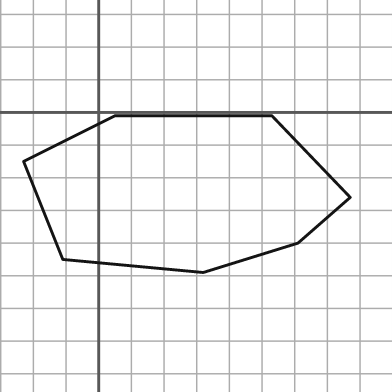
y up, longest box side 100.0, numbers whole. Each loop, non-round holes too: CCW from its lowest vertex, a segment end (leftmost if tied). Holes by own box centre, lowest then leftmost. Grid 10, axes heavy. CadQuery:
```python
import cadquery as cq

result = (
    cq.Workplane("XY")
    .moveTo(32.0, -49.0)
    .lineTo(61.0, -40.0)
    .lineTo(77.0, -26.0)
    .lineTo(53.0, -1.0)
    .lineTo(5.0, -1.0)
    .lineTo(-23.0, -15.0)
    .lineTo(-11.0, -45.0)
    .close()
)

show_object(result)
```